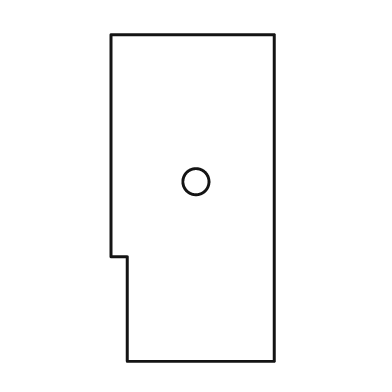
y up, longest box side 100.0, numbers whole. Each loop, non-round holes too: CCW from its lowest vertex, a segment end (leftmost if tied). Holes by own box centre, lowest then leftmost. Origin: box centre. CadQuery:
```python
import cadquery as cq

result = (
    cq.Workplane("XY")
    .moveTo(-20.0, -50.0)
    .lineTo(25.0, -50.0)
    .lineTo(25.0, 50.0)
    .lineTo(-25.0, 50.0)
    .lineTo(-25.0, -18.0)
    .lineTo(-20.0, -18.0)
    .close()
    .moveTo(1.0, 5.0)
    .circle(4.0)
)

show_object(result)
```